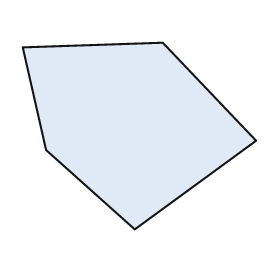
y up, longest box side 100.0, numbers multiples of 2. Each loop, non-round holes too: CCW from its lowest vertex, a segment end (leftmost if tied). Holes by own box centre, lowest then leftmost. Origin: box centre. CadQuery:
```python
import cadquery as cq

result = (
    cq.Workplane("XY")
    .moveTo(-2.0, -40.0)
    .lineTo(50.0, -2.0)
    .lineTo(10.0, 40.0)
    .lineTo(-50.0, 38.0)
    .lineTo(-40.0, -6.0)
    .close()
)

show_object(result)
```